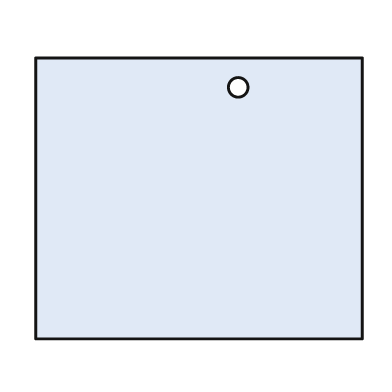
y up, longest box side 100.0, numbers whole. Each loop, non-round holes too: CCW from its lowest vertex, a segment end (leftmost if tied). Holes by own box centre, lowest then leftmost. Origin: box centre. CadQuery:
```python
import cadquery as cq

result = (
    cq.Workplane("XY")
    .moveTo(-50.0, -43.0)
    .lineTo(50.0, -43.0)
    .lineTo(50.0, 43.0)
    .lineTo(-50.0, 43.0)
    .close()
    .moveTo(12.0, 34.0)
    .circle(3.0)
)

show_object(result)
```